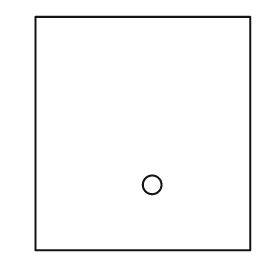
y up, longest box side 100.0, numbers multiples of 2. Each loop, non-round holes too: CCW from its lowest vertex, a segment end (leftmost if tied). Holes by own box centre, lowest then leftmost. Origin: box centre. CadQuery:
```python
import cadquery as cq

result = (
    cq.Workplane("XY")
    .moveTo(-46.0, -50.0)
    .lineTo(46.0, -50.0)
    .lineTo(46.0, 50.0)
    .lineTo(-46.0, 50.0)
    .close()
    .moveTo(4.0, -22.0)
    .circle(4.0)
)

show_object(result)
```